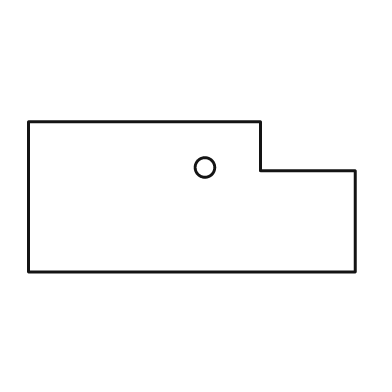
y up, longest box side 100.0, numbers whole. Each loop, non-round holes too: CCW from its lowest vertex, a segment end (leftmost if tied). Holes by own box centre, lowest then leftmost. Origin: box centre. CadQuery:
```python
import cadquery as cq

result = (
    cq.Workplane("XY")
    .moveTo(-50.0, -23.0)
    .lineTo(50.0, -23.0)
    .lineTo(50.0, 8.0)
    .lineTo(21.0, 8.0)
    .lineTo(21.0, 23.0)
    .lineTo(-50.0, 23.0)
    .close()
    .moveTo(4.0, 9.0)
    .circle(3.0)
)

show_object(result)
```